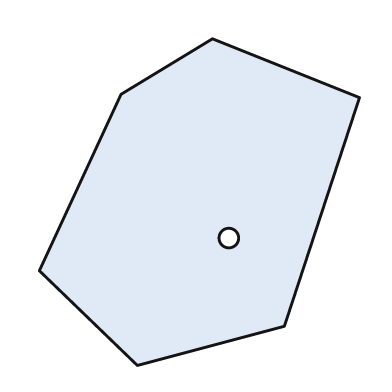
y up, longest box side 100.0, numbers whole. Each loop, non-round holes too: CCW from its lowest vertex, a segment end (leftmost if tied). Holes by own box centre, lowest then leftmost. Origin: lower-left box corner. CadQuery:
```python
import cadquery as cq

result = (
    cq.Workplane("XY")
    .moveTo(30.0, 0.0)
    .lineTo(75.0, 12.0)
    .lineTo(98.0, 82.0)
    .lineTo(53.0, 100.0)
    .lineTo(25.0, 83.0)
    .lineTo(0.0, 29.0)
    .close()
    .moveTo(58.0, 39.0)
    .circle(3.0)
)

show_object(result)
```